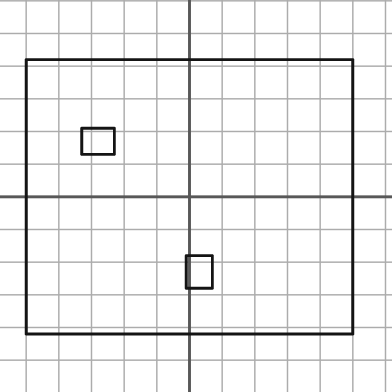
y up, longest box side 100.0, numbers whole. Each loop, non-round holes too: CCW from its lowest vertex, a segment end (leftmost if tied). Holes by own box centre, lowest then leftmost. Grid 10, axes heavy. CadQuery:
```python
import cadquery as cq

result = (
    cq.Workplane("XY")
    .moveTo(-50.0, -42.0)
    .lineTo(50.0, -42.0)
    .lineTo(50.0, 42.0)
    .lineTo(-50.0, 42.0)
    .close()
    .moveTo(-1.0, -28.0)
    .lineTo(7.0, -28.0)
    .lineTo(7.0, -18.0)
    .lineTo(-1.0, -18.0)
    .close()
    .moveTo(-33.0, 13.0)
    .lineTo(-23.0, 13.0)
    .lineTo(-23.0, 21.0)
    .lineTo(-33.0, 21.0)
    .close()
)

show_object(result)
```